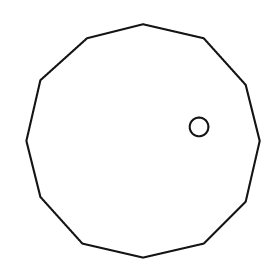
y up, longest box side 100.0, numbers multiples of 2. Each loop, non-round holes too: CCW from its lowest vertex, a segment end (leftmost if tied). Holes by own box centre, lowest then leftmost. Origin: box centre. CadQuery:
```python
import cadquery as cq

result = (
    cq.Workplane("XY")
    .moveTo(0.0, -50.0)
    .lineTo(26.0, -44.0)
    .lineTo(44.0, -26.0)
    .lineTo(50.0, 0.0)
    .lineTo(44.0, 24.0)
    .lineTo(26.0, 44.0)
    .lineTo(0.0, 50.0)
    .lineTo(-24.0, 44.0)
    .lineTo(-44.0, 26.0)
    .lineTo(-50.0, 0.0)
    .lineTo(-44.0, -24.0)
    .lineTo(-26.0, -44.0)
    .close()
    .moveTo(24.0, 6.0)
    .circle(4.0)
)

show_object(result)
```